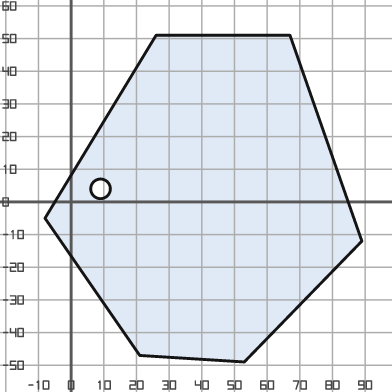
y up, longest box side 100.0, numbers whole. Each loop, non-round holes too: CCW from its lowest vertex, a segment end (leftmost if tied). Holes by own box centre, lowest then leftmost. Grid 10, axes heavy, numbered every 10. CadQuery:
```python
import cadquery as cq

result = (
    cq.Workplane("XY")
    .moveTo(53.0, -49.0)
    .lineTo(89.0, -12.0)
    .lineTo(67.0, 51.0)
    .lineTo(26.0, 51.0)
    .lineTo(-8.0, -5.0)
    .lineTo(21.0, -47.0)
    .close()
    .moveTo(9.0, 4.0)
    .circle(3.0)
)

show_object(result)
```